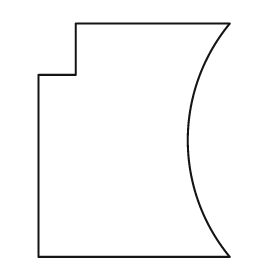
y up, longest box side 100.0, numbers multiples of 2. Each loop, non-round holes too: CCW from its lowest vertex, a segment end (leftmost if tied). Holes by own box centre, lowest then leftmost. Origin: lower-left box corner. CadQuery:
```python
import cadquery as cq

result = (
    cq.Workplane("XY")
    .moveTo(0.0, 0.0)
    .lineTo(82.0, 0.0)
    .threePointArc((64.0, 50.0), (82.0, 100.0))
    .lineTo(16.0, 100.0)
    .lineTo(16.0, 78.0)
    .lineTo(0.0, 78.0)
    .close()
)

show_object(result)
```